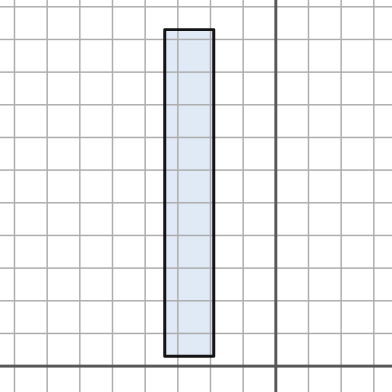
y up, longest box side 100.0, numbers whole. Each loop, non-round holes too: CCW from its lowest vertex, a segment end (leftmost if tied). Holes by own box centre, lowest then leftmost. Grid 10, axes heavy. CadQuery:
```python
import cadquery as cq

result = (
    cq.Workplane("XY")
    .moveTo(-34.0, 3.0)
    .lineTo(-19.0, 3.0)
    .lineTo(-19.0, 103.0)
    .lineTo(-34.0, 103.0)
    .close()
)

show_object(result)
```